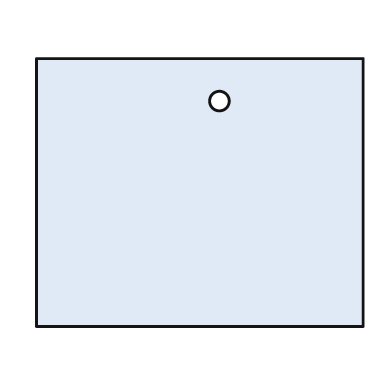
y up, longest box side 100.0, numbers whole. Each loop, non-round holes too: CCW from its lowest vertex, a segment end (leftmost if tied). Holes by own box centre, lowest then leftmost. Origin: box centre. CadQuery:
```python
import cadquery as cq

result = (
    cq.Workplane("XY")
    .moveTo(-50.0, -41.0)
    .lineTo(50.0, -41.0)
    .lineTo(50.0, 41.0)
    .lineTo(-50.0, 41.0)
    .close()
    .moveTo(6.0, 28.0)
    .circle(3.0)
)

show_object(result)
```